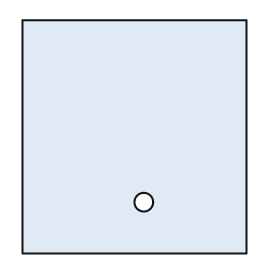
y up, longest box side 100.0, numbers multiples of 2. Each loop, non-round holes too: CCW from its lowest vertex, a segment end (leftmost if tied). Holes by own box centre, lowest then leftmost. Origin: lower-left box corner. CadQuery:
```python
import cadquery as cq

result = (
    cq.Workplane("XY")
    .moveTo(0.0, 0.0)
    .lineTo(96.0, 0.0)
    .lineTo(96.0, 100.0)
    .lineTo(0.0, 100.0)
    .close()
    .moveTo(52.0, 22.0)
    .circle(4.0)
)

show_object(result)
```